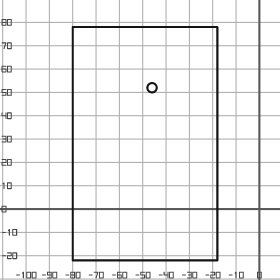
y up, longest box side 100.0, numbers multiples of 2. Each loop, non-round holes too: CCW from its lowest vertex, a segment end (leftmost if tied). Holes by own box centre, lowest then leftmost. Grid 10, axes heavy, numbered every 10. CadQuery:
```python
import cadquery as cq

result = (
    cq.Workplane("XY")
    .moveTo(-80.0, -22.0)
    .lineTo(-18.0, -22.0)
    .lineTo(-18.0, 78.0)
    .lineTo(-80.0, 78.0)
    .close()
    .moveTo(-46.0, 52.0)
    .circle(2.0)
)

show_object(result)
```